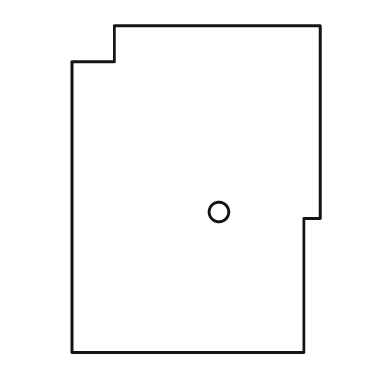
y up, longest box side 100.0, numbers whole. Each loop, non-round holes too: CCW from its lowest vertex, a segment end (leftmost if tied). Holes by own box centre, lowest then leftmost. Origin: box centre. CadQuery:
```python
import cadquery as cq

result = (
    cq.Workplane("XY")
    .moveTo(-38.0, -50.0)
    .lineTo(33.0, -50.0)
    .lineTo(33.0, -9.0)
    .lineTo(38.0, -9.0)
    .lineTo(38.0, 50.0)
    .lineTo(-25.0, 50.0)
    .lineTo(-25.0, 39.0)
    .lineTo(-38.0, 39.0)
    .close()
    .moveTo(7.0, -7.0)
    .circle(3.0)
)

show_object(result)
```